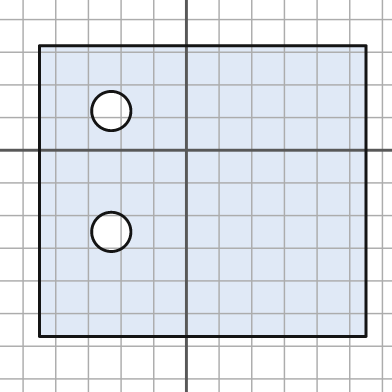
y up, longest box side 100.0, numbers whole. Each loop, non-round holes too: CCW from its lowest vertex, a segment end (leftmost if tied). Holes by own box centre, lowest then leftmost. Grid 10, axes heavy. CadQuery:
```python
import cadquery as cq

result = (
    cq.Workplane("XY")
    .moveTo(-45.0, -57.0)
    .lineTo(55.0, -57.0)
    .lineTo(55.0, 32.0)
    .lineTo(-45.0, 32.0)
    .close()
    .moveTo(-23.0, -25.0)
    .circle(6.0)
    .moveTo(-23.0, 12.0)
    .circle(6.0)
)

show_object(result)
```